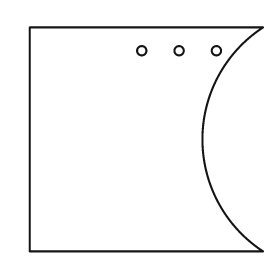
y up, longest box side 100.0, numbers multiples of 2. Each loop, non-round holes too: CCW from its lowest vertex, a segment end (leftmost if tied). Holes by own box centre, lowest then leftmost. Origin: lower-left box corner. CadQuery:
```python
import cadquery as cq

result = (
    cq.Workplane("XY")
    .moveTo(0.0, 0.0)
    .lineTo(100.0, 0.0)
    .threePointArc((74.0, 48.0), (100.0, 96.0))
    .lineTo(0.0, 96.0)
    .close()
    .moveTo(48.0, 86.0)
    .circle(2.0)
    .moveTo(64.0, 86.0)
    .circle(2.0)
    .moveTo(80.0, 86.0)
    .circle(2.0)
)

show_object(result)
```